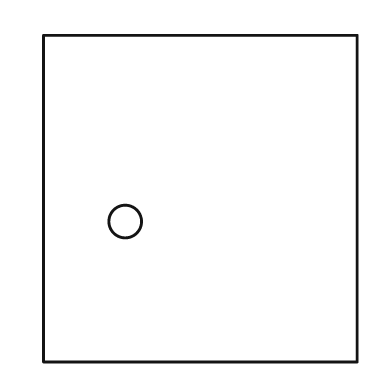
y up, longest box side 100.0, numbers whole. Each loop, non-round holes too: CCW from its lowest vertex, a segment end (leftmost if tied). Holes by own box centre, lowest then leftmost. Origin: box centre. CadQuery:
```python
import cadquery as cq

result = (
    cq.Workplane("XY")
    .moveTo(-48.0, -50.0)
    .lineTo(48.0, -50.0)
    .lineTo(48.0, 50.0)
    .lineTo(-48.0, 50.0)
    .close()
    .moveTo(-23.0, -7.0)
    .circle(5.0)
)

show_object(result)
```